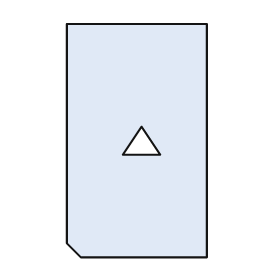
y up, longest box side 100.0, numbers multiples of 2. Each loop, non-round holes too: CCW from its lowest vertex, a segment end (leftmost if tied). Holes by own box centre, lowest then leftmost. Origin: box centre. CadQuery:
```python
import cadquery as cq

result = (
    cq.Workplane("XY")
    .moveTo(-24.0, -50.0)
    .lineTo(30.0, -50.0)
    .lineTo(30.0, 50.0)
    .lineTo(-30.0, 50.0)
    .lineTo(-30.0, -44.0)
    .close()
    .moveTo(-6.0, -6.0)
    .lineTo(10.0, -6.0)
    .lineTo(2.0, 6.0)
    .close()
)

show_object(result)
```